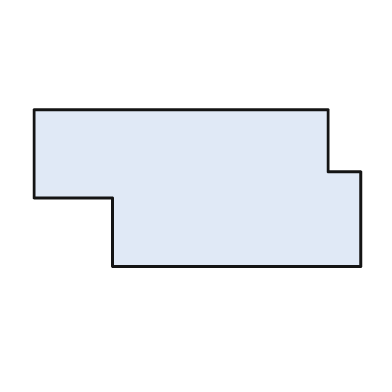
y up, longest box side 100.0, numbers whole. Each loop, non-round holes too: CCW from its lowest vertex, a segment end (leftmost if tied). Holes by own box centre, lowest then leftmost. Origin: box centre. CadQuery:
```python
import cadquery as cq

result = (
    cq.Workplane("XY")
    .moveTo(-26.0, -24.0)
    .lineTo(50.0, -24.0)
    .lineTo(50.0, 5.0)
    .lineTo(40.0, 5.0)
    .lineTo(40.0, 24.0)
    .lineTo(-50.0, 24.0)
    .lineTo(-50.0, -3.0)
    .lineTo(-26.0, -3.0)
    .close()
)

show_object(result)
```